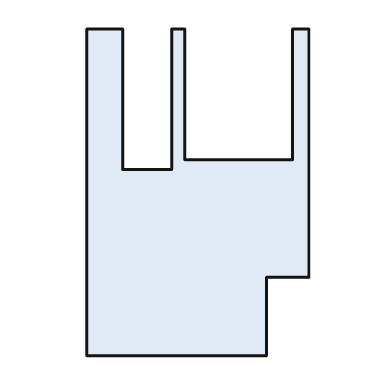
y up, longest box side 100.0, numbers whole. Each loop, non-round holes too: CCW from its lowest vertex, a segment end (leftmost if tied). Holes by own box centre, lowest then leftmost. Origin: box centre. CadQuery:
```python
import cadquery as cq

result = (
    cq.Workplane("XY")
    .moveTo(-34.0, -50.0)
    .lineTo(21.0, -50.0)
    .lineTo(21.0, -26.0)
    .lineTo(34.0, -26.0)
    .lineTo(34.0, 50.0)
    .lineTo(29.0, 50.0)
    .lineTo(29.0, 10.0)
    .lineTo(-4.0, 10.0)
    .lineTo(-4.0, 50.0)
    .lineTo(-8.0, 50.0)
    .lineTo(-8.0, 7.0)
    .lineTo(-23.0, 7.0)
    .lineTo(-23.0, 50.0)
    .lineTo(-34.0, 50.0)
    .close()
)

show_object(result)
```